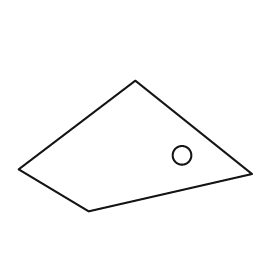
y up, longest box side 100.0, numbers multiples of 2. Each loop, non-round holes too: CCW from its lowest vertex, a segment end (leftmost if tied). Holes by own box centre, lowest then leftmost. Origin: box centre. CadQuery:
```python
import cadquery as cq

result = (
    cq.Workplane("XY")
    .moveTo(-20.0, -28.0)
    .lineTo(50.0, -12.0)
    .lineTo(0.0, 28.0)
    .lineTo(-50.0, -10.0)
    .close()
    .moveTo(20.0, -4.0)
    .circle(4.0)
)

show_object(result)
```